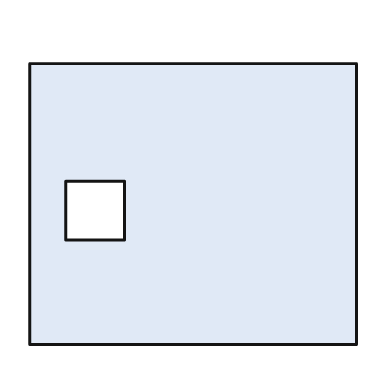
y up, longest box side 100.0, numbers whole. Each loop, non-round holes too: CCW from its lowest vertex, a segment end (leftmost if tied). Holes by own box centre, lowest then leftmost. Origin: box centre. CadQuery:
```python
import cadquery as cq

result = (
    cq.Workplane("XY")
    .moveTo(-50.0, -43.0)
    .lineTo(50.0, -43.0)
    .lineTo(50.0, 43.0)
    .lineTo(-50.0, 43.0)
    .close()
    .moveTo(-39.0, -11.0)
    .lineTo(-21.0, -11.0)
    .lineTo(-21.0, 7.0)
    .lineTo(-39.0, 7.0)
    .close()
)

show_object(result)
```